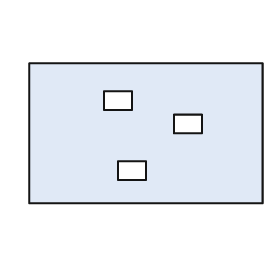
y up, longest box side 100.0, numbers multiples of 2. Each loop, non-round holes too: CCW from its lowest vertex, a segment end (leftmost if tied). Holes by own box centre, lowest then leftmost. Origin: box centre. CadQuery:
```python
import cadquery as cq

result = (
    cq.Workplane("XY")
    .moveTo(-50.0, -30.0)
    .lineTo(50.0, -30.0)
    .lineTo(50.0, 30.0)
    .lineTo(-50.0, 30.0)
    .close()
    .moveTo(-12.0, -20.0)
    .lineTo(0.0, -20.0)
    .lineTo(0.0, -12.0)
    .lineTo(-12.0, -12.0)
    .close()
    .moveTo(12.0, 0.0)
    .lineTo(24.0, 0.0)
    .lineTo(24.0, 8.0)
    .lineTo(12.0, 8.0)
    .close()
    .moveTo(-18.0, 10.0)
    .lineTo(-6.0, 10.0)
    .lineTo(-6.0, 18.0)
    .lineTo(-18.0, 18.0)
    .close()
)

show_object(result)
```